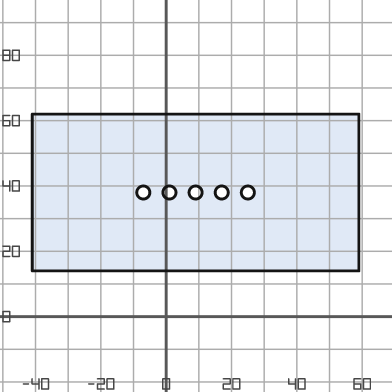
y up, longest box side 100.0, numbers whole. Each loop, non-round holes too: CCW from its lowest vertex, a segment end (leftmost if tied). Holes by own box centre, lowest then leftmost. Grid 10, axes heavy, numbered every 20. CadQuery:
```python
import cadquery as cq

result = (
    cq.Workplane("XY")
    .moveTo(-41.0, 14.0)
    .lineTo(59.0, 14.0)
    .lineTo(59.0, 62.0)
    .lineTo(-41.0, 62.0)
    .close()
    .moveTo(-7.0, 38.0)
    .circle(2.0)
    .moveTo(1.0, 38.0)
    .circle(2.0)
    .moveTo(9.0, 38.0)
    .circle(2.0)
    .moveTo(17.0, 38.0)
    .circle(2.0)
    .moveTo(25.0, 38.0)
    .circle(2.0)
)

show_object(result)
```